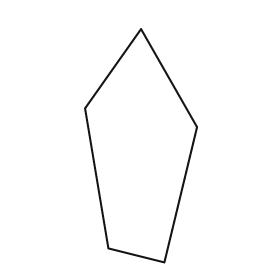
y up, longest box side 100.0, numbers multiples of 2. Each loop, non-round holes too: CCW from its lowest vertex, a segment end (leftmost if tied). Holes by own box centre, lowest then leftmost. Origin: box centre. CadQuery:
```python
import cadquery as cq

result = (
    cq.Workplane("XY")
    .moveTo(10.0, -50.0)
    .lineTo(24.0, 8.0)
    .lineTo(0.0, 50.0)
    .lineTo(-24.0, 16.0)
    .lineTo(-14.0, -44.0)
    .close()
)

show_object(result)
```